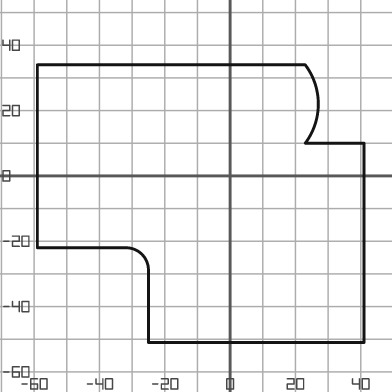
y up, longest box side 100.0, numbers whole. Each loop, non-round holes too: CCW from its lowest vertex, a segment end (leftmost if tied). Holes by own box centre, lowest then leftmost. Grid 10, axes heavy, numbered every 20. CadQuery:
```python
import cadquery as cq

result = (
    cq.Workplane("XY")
    .moveTo(-25.0, -51.0)
    .lineTo(41.0, -51.0)
    .lineTo(41.0, 10.0)
    .lineTo(23.0, 10.0)
    .threePointArc((27.0, 22.0), (23.0, 34.0))
    .lineTo(-59.0, 34.0)
    .lineTo(-59.0, -22.0)
    .lineTo(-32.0, -22.0)
    .threePointArc((-27.0, -24.0), (-25.0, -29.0))
    .close()
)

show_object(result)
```